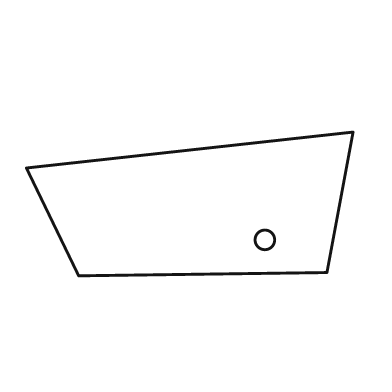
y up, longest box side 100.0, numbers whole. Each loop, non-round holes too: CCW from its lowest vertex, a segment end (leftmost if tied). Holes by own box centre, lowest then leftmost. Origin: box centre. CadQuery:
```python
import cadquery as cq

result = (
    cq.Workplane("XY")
    .moveTo(-34.0, -22.0)
    .lineTo(42.0, -21.0)
    .lineTo(50.0, 22.0)
    .lineTo(-50.0, 11.0)
    .close()
    .moveTo(23.0, -11.0)
    .circle(3.0)
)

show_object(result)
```